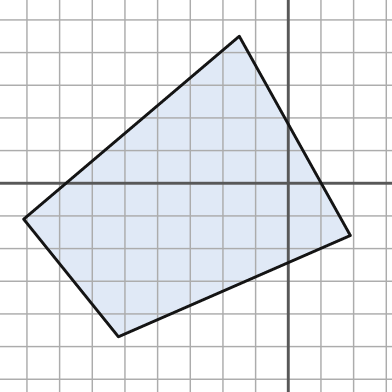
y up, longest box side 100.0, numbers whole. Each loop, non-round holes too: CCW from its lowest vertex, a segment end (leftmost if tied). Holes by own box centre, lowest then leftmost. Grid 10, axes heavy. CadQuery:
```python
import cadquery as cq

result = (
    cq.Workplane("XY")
    .moveTo(-52.0, -47.0)
    .lineTo(19.0, -16.0)
    .lineTo(-15.0, 45.0)
    .lineTo(-81.0, -11.0)
    .close()
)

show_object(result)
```